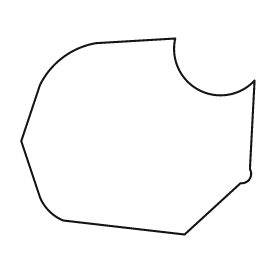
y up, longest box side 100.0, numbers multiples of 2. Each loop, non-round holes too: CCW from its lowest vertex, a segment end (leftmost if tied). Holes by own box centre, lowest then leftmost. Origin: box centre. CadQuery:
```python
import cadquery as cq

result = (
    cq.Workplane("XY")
    .moveTo(20.0, -42.0)
    .lineTo(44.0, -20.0)
    .threePointArc((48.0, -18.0), (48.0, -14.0))
    .lineTo(50.0, 24.0)
    .threePointArc((26.0, 20.0), (16.0, 42.0))
    .lineTo(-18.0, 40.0)
    .threePointArc((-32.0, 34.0), (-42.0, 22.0))
    .lineTo(-50.0, -2.0)
    .lineTo(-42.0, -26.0)
    .threePointArc((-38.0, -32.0), (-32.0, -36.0))
    .close()
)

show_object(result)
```